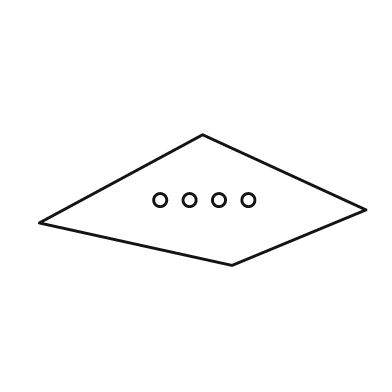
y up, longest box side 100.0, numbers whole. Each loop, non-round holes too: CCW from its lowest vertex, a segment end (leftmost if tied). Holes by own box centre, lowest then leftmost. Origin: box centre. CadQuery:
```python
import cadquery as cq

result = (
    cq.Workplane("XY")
    .moveTo(9.0, -20.0)
    .lineTo(50.0, -3.0)
    .lineTo(0.0, 20.0)
    .lineTo(-50.0, -7.0)
    .close()
    .moveTo(-13.0, 0.0)
    .circle(2.0)
    .moveTo(-4.0, 0.0)
    .circle(2.0)
    .moveTo(5.0, 0.0)
    .circle(2.0)
    .moveTo(14.0, 0.0)
    .circle(2.0)
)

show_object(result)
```